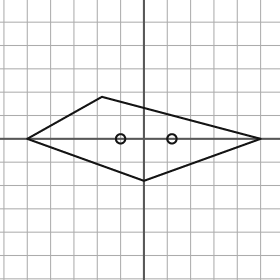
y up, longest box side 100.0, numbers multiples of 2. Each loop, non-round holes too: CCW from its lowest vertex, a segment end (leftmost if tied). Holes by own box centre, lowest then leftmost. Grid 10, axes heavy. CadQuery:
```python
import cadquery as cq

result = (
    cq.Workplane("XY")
    .moveTo(0.0, -18.0)
    .lineTo(50.0, 0.0)
    .lineTo(-18.0, 18.0)
    .lineTo(-50.0, 0.0)
    .close()
    .moveTo(-10.0, 0.0)
    .circle(2.0)
    .moveTo(12.0, 0.0)
    .circle(2.0)
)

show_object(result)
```